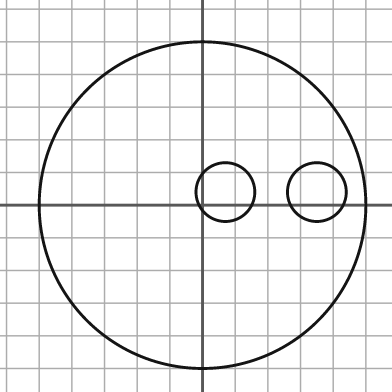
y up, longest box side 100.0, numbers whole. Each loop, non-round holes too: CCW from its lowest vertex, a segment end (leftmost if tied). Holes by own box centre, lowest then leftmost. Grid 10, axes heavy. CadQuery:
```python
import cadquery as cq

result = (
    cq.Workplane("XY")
    .moveTo(0.0, 0.0)
    .circle(50.0)
    .moveTo(7.0, 4.0)
    .circle(9.0)
    .moveTo(35.0, 4.0)
    .circle(9.0)
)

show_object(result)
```